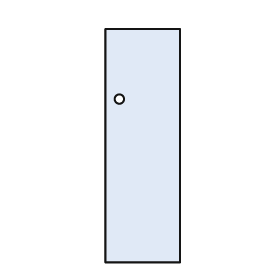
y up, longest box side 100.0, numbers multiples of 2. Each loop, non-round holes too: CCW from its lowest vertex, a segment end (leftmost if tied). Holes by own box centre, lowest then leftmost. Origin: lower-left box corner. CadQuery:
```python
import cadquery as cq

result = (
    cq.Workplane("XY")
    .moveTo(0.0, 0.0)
    .lineTo(32.0, 0.0)
    .lineTo(32.0, 100.0)
    .lineTo(0.0, 100.0)
    .close()
    .moveTo(6.0, 70.0)
    .circle(2.0)
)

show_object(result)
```